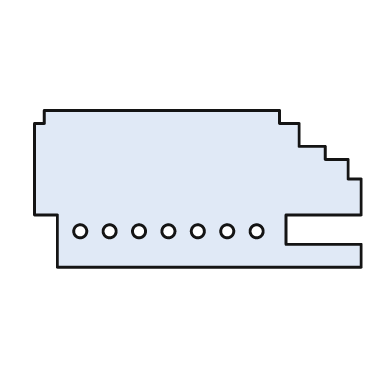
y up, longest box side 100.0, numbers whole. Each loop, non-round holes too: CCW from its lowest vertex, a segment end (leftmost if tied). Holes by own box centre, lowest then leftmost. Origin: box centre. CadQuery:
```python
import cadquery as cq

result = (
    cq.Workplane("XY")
    .moveTo(-43.0, -24.0)
    .lineTo(50.0, -24.0)
    .lineTo(50.0, -17.0)
    .lineTo(27.0, -17.0)
    .lineTo(27.0, -8.0)
    .lineTo(50.0, -8.0)
    .lineTo(50.0, 3.0)
    .lineTo(46.0, 3.0)
    .lineTo(46.0, 9.0)
    .lineTo(39.0, 9.0)
    .lineTo(39.0, 13.0)
    .lineTo(31.0, 13.0)
    .lineTo(31.0, 20.0)
    .lineTo(25.0, 20.0)
    .lineTo(25.0, 24.0)
    .lineTo(-47.0, 24.0)
    .lineTo(-47.0, 20.0)
    .lineTo(-50.0, 20.0)
    .lineTo(-50.0, -8.0)
    .lineTo(-43.0, -8.0)
    .close()
    .moveTo(-36.0, -13.0)
    .circle(2.0)
    .moveTo(-27.0, -13.0)
    .circle(2.0)
    .moveTo(-18.0, -13.0)
    .circle(2.0)
    .moveTo(-9.0, -13.0)
    .circle(2.0)
    .moveTo(0.0, -13.0)
    .circle(2.0)
    .moveTo(9.0, -13.0)
    .circle(2.0)
    .moveTo(18.0, -13.0)
    .circle(2.0)
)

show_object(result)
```